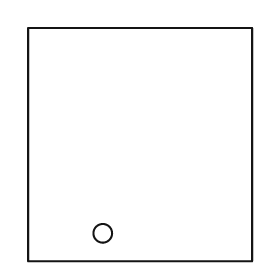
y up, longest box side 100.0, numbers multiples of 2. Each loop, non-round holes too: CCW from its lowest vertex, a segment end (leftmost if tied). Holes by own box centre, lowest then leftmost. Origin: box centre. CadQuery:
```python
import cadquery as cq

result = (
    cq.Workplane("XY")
    .moveTo(-48.0, -50.0)
    .lineTo(48.0, -50.0)
    .lineTo(48.0, 50.0)
    .lineTo(-48.0, 50.0)
    .close()
    .moveTo(-16.0, -38.0)
    .circle(4.0)
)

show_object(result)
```